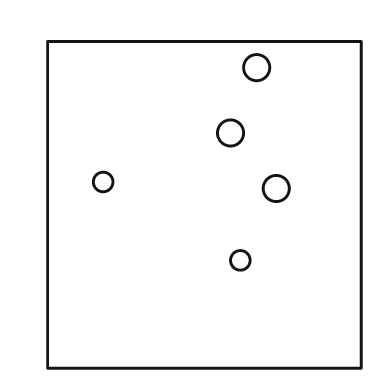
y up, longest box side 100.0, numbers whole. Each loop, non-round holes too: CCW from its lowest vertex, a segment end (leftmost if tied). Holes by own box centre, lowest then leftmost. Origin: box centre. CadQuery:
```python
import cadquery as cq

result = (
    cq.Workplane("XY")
    .moveTo(-48.0, -50.0)
    .lineTo(48.0, -50.0)
    .lineTo(48.0, 50.0)
    .lineTo(-48.0, 50.0)
    .close()
    .moveTo(11.0, -17.0)
    .circle(3.0)
    .moveTo(22.0, 5.0)
    .circle(4.0)
    .moveTo(-31.0, 7.0)
    .circle(3.0)
    .moveTo(8.0, 22.0)
    .circle(4.0)
    .moveTo(16.0, 42.0)
    .circle(4.0)
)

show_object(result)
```